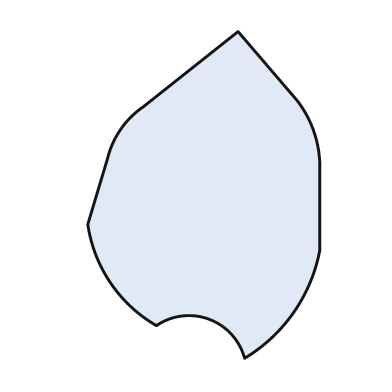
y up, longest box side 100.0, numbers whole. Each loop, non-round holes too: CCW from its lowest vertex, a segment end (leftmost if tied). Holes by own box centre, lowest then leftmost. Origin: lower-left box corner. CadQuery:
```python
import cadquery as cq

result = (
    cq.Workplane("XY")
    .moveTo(48.0, 0.0)
    .threePointArc((63.0, 14.0), (71.0, 33.0))
    .lineTo(71.0, 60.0)
    .threePointArc((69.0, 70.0), (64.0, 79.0))
    .lineTo(46.0, 100.0)
    .lineTo(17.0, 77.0)
    .threePointArc((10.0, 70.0), (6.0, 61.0))
    .lineTo(0.0, 41.0)
    .threePointArc((7.0, 23.0), (21.0, 10.0))
    .threePointArc((37.0, 12.0), (48.0, 0.0))
    .close()
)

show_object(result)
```